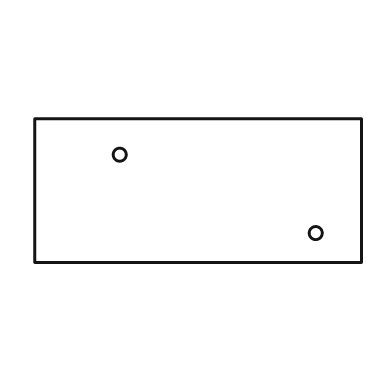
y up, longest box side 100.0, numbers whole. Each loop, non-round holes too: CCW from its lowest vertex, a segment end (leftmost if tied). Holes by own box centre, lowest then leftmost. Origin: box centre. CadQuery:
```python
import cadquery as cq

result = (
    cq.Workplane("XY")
    .moveTo(-50.0, -22.0)
    .lineTo(50.0, -22.0)
    .lineTo(50.0, 22.0)
    .lineTo(-50.0, 22.0)
    .close()
    .moveTo(36.0, -13.0)
    .circle(2.0)
    .moveTo(-24.0, 11.0)
    .circle(2.0)
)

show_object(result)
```